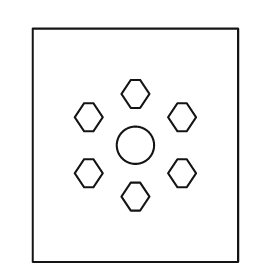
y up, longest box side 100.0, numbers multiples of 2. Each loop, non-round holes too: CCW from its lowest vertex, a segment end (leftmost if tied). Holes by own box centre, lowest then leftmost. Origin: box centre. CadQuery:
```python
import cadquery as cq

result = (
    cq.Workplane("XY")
    .moveTo(-44.0, -50.0)
    .lineTo(44.0, -50.0)
    .lineTo(44.0, 50.0)
    .lineTo(-44.0, 50.0)
    .close()
    .moveTo(-2.0, -28.0)
    .lineTo(2.0, -28.0)
    .lineTo(6.0, -22.0)
    .lineTo(2.0, -16.0)
    .lineTo(-2.0, -16.0)
    .lineTo(-6.0, -22.0)
    .close()
    .moveTo(-22.0, -18.0)
    .lineTo(-18.0, -18.0)
    .lineTo(-14.0, -12.0)
    .lineTo(-18.0, -6.0)
    .lineTo(-22.0, -6.0)
    .lineTo(-26.0, -12.0)
    .close()
    .moveTo(18.0, -18.0)
    .lineTo(22.0, -18.0)
    .lineTo(26.0, -12.0)
    .lineTo(22.0, -6.0)
    .lineTo(18.0, -6.0)
    .lineTo(14.0, -12.0)
    .close()
    .moveTo(0.0, 0.0)
    .circle(8.0)
    .moveTo(-22.0, 6.0)
    .lineTo(-18.0, 6.0)
    .lineTo(-14.0, 12.0)
    .lineTo(-18.0, 18.0)
    .lineTo(-22.0, 18.0)
    .lineTo(-26.0, 12.0)
    .close()
    .moveTo(18.0, 6.0)
    .lineTo(22.0, 6.0)
    .lineTo(26.0, 12.0)
    .lineTo(22.0, 18.0)
    .lineTo(18.0, 18.0)
    .lineTo(14.0, 12.0)
    .close()
    .moveTo(-2.0, 16.0)
    .lineTo(2.0, 16.0)
    .lineTo(6.0, 22.0)
    .lineTo(2.0, 28.0)
    .lineTo(-2.0, 28.0)
    .lineTo(-6.0, 22.0)
    .close()
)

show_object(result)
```